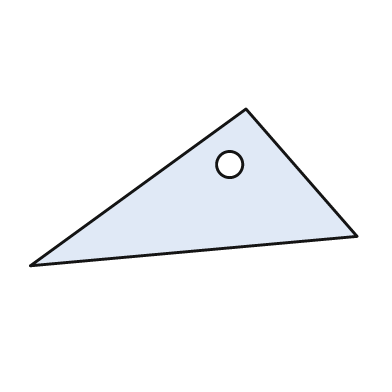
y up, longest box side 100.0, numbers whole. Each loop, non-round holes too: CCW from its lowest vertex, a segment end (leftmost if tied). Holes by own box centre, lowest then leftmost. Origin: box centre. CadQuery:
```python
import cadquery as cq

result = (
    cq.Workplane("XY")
    .moveTo(-50.0, -24.0)
    .lineTo(50.0, -15.0)
    .lineTo(16.0, 24.0)
    .close()
    .moveTo(11.0, 7.0)
    .circle(4.0)
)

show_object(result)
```